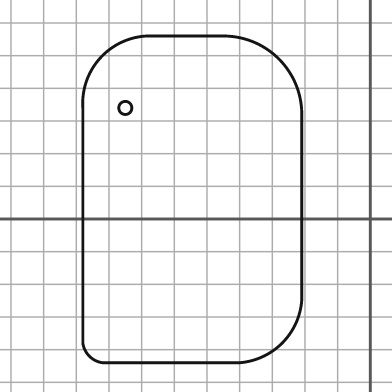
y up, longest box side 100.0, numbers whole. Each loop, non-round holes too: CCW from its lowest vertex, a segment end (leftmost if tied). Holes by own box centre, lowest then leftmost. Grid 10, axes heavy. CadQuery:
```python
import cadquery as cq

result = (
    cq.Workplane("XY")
    .moveTo(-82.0, -44.0)
    .lineTo(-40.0, -44.0)
    .threePointArc((-27.0, -38.0), (-21.0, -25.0))
    .lineTo(-21.0, 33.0)
    .threePointArc((-28.0, 49.0), (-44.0, 56.0))
    .lineTo(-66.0, 56.0)
    .threePointArc((-82.0, 50.0), (-88.0, 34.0))
    .lineTo(-88.0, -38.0)
    .threePointArc((-86.0, -42.0), (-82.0, -44.0))
    .close()
    .moveTo(-75.0, 34.0)
    .circle(2.0)
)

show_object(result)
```